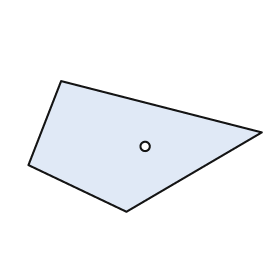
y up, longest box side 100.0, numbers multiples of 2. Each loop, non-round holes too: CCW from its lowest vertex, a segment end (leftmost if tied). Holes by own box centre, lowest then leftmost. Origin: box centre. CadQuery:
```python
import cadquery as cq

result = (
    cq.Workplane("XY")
    .moveTo(-8.0, -28.0)
    .lineTo(50.0, 6.0)
    .lineTo(-36.0, 28.0)
    .lineTo(-50.0, -8.0)
    .close()
    .moveTo(0.0, 0.0)
    .circle(2.0)
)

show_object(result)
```